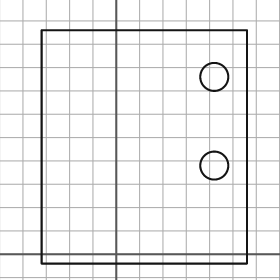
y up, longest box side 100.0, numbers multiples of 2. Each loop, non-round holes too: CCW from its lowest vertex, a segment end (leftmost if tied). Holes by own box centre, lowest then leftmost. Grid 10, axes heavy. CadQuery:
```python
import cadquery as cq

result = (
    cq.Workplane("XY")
    .moveTo(-32.0, -4.0)
    .lineTo(56.0, -4.0)
    .lineTo(56.0, 96.0)
    .lineTo(-32.0, 96.0)
    .close()
    .moveTo(42.0, 38.0)
    .circle(6.0)
    .moveTo(42.0, 76.0)
    .circle(6.0)
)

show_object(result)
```